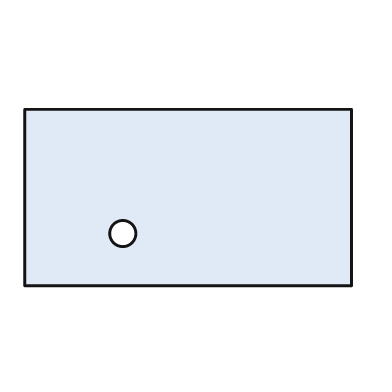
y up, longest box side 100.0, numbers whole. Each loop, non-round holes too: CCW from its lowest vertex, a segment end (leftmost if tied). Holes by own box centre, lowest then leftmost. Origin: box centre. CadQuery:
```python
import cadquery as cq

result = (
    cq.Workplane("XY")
    .moveTo(-50.0, -27.0)
    .lineTo(50.0, -27.0)
    .lineTo(50.0, 27.0)
    .lineTo(-50.0, 27.0)
    .close()
    .moveTo(-20.0, -11.0)
    .circle(4.0)
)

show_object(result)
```